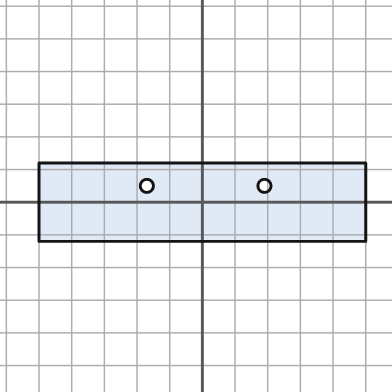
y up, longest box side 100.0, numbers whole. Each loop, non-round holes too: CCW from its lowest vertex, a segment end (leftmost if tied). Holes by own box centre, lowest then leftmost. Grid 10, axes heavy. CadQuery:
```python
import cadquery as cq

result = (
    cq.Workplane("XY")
    .moveTo(-50.0, -12.0)
    .lineTo(50.0, -12.0)
    .lineTo(50.0, 12.0)
    .lineTo(-50.0, 12.0)
    .close()
    .moveTo(-17.0, 5.0)
    .circle(2.0)
    .moveTo(19.0, 5.0)
    .circle(2.0)
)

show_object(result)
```